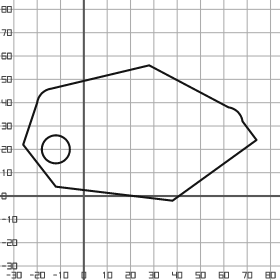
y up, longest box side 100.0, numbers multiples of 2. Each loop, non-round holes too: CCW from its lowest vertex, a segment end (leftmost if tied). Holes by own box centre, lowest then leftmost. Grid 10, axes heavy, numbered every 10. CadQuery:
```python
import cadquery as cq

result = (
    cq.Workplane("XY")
    .moveTo(38.0, -2.0)
    .lineTo(74.0, 24.0)
    .lineTo(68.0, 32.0)
    .threePointArc((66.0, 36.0), (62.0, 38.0))
    .lineTo(28.0, 56.0)
    .lineTo(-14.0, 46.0)
    .threePointArc((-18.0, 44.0), (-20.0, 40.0))
    .lineTo(-26.0, 22.0)
    .lineTo(-12.0, 4.0)
    .close()
    .moveTo(-12.0, 20.0)
    .circle(6.0)
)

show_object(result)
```